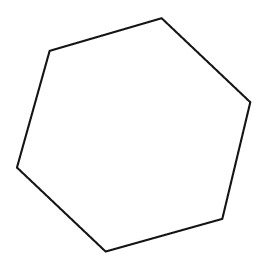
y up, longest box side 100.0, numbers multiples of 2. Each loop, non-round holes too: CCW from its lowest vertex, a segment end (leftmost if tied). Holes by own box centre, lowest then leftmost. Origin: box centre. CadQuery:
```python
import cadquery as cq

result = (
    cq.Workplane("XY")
    .moveTo(-12.0, -50.0)
    .lineTo(38.0, -36.0)
    .lineTo(50.0, 14.0)
    .lineTo(12.0, 50.0)
    .lineTo(-36.0, 36.0)
    .lineTo(-50.0, -14.0)
    .close()
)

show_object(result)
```